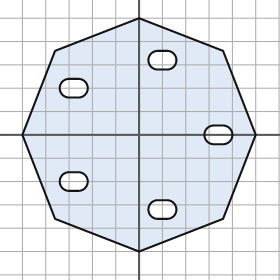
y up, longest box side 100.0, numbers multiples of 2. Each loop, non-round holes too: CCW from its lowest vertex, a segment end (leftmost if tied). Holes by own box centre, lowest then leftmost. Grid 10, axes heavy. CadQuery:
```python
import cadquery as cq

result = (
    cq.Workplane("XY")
    .moveTo(0.0, -50.0)
    .lineTo(36.0, -36.0)
    .lineTo(50.0, 0.0)
    .lineTo(36.0, 36.0)
    .lineTo(0.0, 50.0)
    .lineTo(-36.0, 36.0)
    .lineTo(-50.0, 0.0)
    .lineTo(-36.0, -36.0)
    .close()
    .moveTo(8.0, -36.0)
    .lineTo(12.0, -36.0)
    .threePointArc((16.0, -32.0), (12.0, -28.0))
    .lineTo(8.0, -28.0)
    .threePointArc((4.0, -32.0), (8.0, -36.0))
    .close()
    .moveTo(-30.0, -24.0)
    .lineTo(-26.0, -24.0)
    .threePointArc((-22.0, -20.0), (-26.0, -16.0))
    .lineTo(-30.0, -16.0)
    .threePointArc((-34.0, -20.0), (-30.0, -24.0))
    .close()
    .moveTo(32.0, -4.0)
    .lineTo(36.0, -4.0)
    .threePointArc((40.0, 0.0), (36.0, 4.0))
    .lineTo(32.0, 4.0)
    .threePointArc((28.0, 0.0), (32.0, -4.0))
    .close()
    .moveTo(-30.0, 16.0)
    .lineTo(-26.0, 16.0)
    .threePointArc((-22.0, 20.0), (-26.0, 24.0))
    .lineTo(-30.0, 24.0)
    .threePointArc((-34.0, 20.0), (-30.0, 16.0))
    .close()
    .moveTo(8.0, 28.0)
    .lineTo(12.0, 28.0)
    .threePointArc((16.0, 32.0), (12.0, 36.0))
    .lineTo(8.0, 36.0)
    .threePointArc((4.0, 32.0), (8.0, 28.0))
    .close()
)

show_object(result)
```